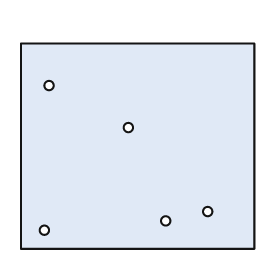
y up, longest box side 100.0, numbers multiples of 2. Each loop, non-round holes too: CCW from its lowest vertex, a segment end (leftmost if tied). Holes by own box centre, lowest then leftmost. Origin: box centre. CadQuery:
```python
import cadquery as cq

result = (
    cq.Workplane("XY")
    .moveTo(-50.0, -44.0)
    .lineTo(50.0, -44.0)
    .lineTo(50.0, 44.0)
    .lineTo(-50.0, 44.0)
    .close()
    .moveTo(-40.0, -36.0)
    .circle(2.0)
    .moveTo(12.0, -32.0)
    .circle(2.0)
    .moveTo(30.0, -28.0)
    .circle(2.0)
    .moveTo(-4.0, 8.0)
    .circle(2.0)
    .moveTo(-38.0, 26.0)
    .circle(2.0)
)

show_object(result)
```